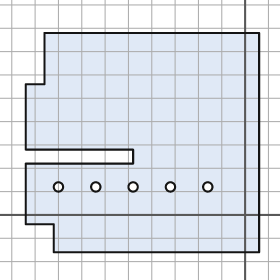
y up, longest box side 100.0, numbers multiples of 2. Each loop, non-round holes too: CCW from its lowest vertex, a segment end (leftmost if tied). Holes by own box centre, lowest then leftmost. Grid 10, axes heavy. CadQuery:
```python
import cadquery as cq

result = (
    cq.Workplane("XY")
    .moveTo(-82.0, -16.0)
    .lineTo(6.0, -16.0)
    .lineTo(6.0, 78.0)
    .lineTo(-86.0, 78.0)
    .lineTo(-86.0, 56.0)
    .lineTo(-94.0, 56.0)
    .lineTo(-94.0, 28.0)
    .lineTo(-48.0, 28.0)
    .lineTo(-48.0, 22.0)
    .lineTo(-94.0, 22.0)
    .lineTo(-94.0, -4.0)
    .lineTo(-82.0, -4.0)
    .close()
    .moveTo(-80.0, 12.0)
    .circle(2.0)
    .moveTo(-64.0, 12.0)
    .circle(2.0)
    .moveTo(-48.0, 12.0)
    .circle(2.0)
    .moveTo(-32.0, 12.0)
    .circle(2.0)
    .moveTo(-16.0, 12.0)
    .circle(2.0)
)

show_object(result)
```